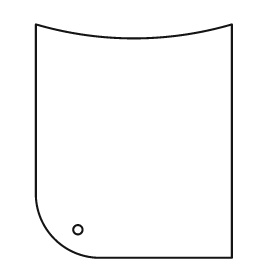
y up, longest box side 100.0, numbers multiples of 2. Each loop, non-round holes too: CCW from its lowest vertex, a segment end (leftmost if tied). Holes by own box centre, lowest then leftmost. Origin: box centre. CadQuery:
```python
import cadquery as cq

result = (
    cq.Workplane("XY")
    .moveTo(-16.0, -50.0)
    .lineTo(42.0, -50.0)
    .lineTo(42.0, 50.0)
    .threePointArc((0.0, 44.0), (-42.0, 50.0))
    .lineTo(-42.0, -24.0)
    .threePointArc((-34.0, -42.0), (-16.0, -50.0))
    .close()
    .moveTo(-24.0, -38.0)
    .circle(2.0)
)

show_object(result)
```